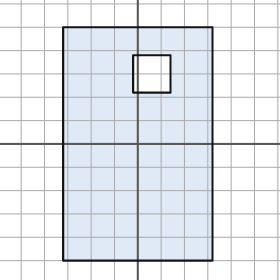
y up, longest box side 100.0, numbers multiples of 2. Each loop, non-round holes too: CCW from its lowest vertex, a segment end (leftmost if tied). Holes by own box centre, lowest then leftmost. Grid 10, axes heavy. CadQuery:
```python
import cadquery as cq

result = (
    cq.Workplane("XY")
    .moveTo(-32.0, -50.0)
    .lineTo(32.0, -50.0)
    .lineTo(32.0, 50.0)
    .lineTo(-32.0, 50.0)
    .close()
    .moveTo(-2.0, 22.0)
    .lineTo(14.0, 22.0)
    .lineTo(14.0, 38.0)
    .lineTo(-2.0, 38.0)
    .close()
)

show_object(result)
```